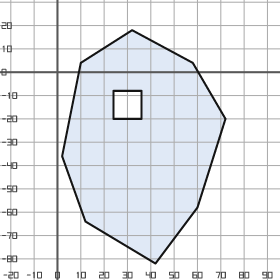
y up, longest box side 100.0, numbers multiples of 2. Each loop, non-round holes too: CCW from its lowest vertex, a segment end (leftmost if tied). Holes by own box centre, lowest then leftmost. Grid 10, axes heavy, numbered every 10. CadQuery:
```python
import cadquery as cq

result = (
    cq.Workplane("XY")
    .moveTo(42.0, -82.0)
    .lineTo(60.0, -58.0)
    .lineTo(72.0, -20.0)
    .lineTo(58.0, 4.0)
    .lineTo(32.0, 18.0)
    .lineTo(10.0, 4.0)
    .lineTo(2.0, -36.0)
    .lineTo(12.0, -64.0)
    .close()
    .moveTo(24.0, -20.0)
    .lineTo(36.0, -20.0)
    .lineTo(36.0, -8.0)
    .lineTo(24.0, -8.0)
    .close()
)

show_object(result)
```